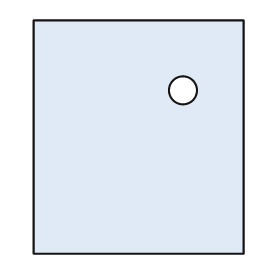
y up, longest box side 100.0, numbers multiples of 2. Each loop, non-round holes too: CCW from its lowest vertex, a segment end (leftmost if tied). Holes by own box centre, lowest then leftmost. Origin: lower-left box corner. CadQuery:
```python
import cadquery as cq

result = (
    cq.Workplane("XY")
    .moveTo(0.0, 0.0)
    .lineTo(90.0, 0.0)
    .lineTo(90.0, 100.0)
    .lineTo(0.0, 100.0)
    .close()
    .moveTo(64.0, 70.0)
    .circle(6.0)
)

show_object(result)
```